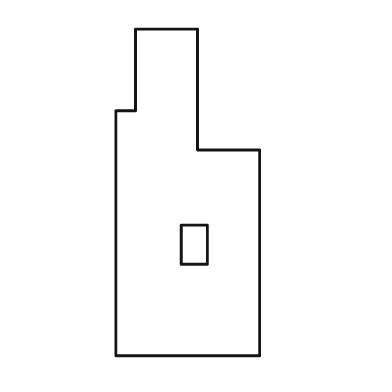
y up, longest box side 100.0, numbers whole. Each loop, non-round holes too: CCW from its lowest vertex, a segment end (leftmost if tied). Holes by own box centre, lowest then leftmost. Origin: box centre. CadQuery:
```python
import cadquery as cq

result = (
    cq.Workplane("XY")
    .moveTo(-22.0, -50.0)
    .lineTo(22.0, -50.0)
    .lineTo(22.0, 13.0)
    .lineTo(3.0, 13.0)
    .lineTo(3.0, 50.0)
    .lineTo(-16.0, 50.0)
    .lineTo(-16.0, 25.0)
    .lineTo(-22.0, 25.0)
    .close()
    .moveTo(-2.0, -22.0)
    .lineTo(6.0, -22.0)
    .lineTo(6.0, -10.0)
    .lineTo(-2.0, -10.0)
    .close()
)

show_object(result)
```